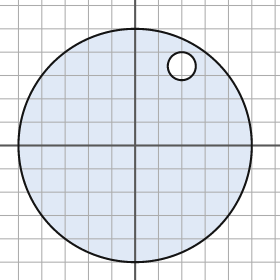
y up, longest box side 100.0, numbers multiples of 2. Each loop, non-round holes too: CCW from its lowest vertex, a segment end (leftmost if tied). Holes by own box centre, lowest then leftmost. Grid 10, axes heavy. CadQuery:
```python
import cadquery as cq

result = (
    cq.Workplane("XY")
    .moveTo(0.0, 0.0)
    .circle(50.0)
    .moveTo(20.0, 34.0)
    .circle(6.0)
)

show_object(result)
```